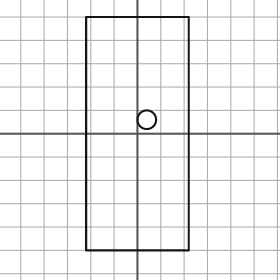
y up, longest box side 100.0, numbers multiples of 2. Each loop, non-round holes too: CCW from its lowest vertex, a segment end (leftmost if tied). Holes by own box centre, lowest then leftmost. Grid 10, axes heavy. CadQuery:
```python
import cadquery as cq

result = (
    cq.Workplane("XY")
    .moveTo(-22.0, -50.0)
    .lineTo(22.0, -50.0)
    .lineTo(22.0, 50.0)
    .lineTo(-22.0, 50.0)
    .close()
    .moveTo(4.0, 6.0)
    .circle(4.0)
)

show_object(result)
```